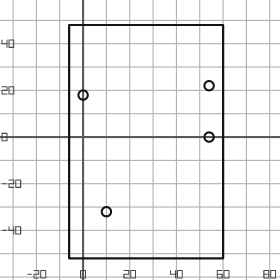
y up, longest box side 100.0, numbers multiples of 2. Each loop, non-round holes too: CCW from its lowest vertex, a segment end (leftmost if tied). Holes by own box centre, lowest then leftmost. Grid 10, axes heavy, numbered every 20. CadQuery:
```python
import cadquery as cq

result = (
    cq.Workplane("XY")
    .moveTo(-6.0, -52.0)
    .lineTo(60.0, -52.0)
    .lineTo(60.0, 48.0)
    .lineTo(-6.0, 48.0)
    .close()
    .moveTo(10.0, -32.0)
    .circle(2.0)
    .moveTo(54.0, 0.0)
    .circle(2.0)
    .moveTo(0.0, 18.0)
    .circle(2.0)
    .moveTo(54.0, 22.0)
    .circle(2.0)
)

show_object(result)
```